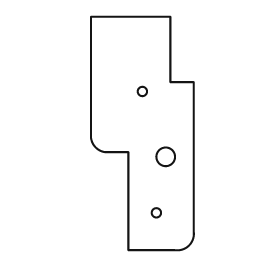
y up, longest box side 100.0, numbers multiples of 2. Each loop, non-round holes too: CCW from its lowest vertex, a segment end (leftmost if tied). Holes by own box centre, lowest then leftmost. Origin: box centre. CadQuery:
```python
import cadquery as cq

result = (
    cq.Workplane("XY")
    .moveTo(-6.0, -50.0)
    .lineTo(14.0, -50.0)
    .threePointArc((20.0, -48.0), (22.0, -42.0))
    .lineTo(22.0, 22.0)
    .lineTo(12.0, 22.0)
    .lineTo(12.0, 50.0)
    .lineTo(-22.0, 50.0)
    .lineTo(-22.0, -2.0)
    .threePointArc((-20.0, -6.0), (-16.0, -8.0))
    .lineTo(-6.0, -8.0)
    .close()
    .moveTo(6.0, -34.0)
    .circle(2.0)
    .moveTo(10.0, -10.0)
    .circle(4.0)
    .moveTo(0.0, 18.0)
    .circle(2.0)
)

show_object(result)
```